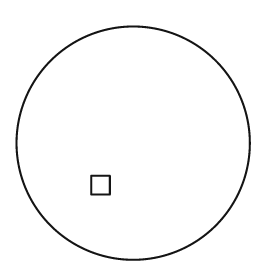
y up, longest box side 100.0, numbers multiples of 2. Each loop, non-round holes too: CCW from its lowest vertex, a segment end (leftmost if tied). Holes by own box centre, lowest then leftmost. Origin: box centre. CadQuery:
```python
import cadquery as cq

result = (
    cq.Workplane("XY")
    .moveTo(0.0, 0.0)
    .circle(50.0)
    .moveTo(-18.0, -22.0)
    .lineTo(-10.0, -22.0)
    .lineTo(-10.0, -14.0)
    .lineTo(-18.0, -14.0)
    .close()
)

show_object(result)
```